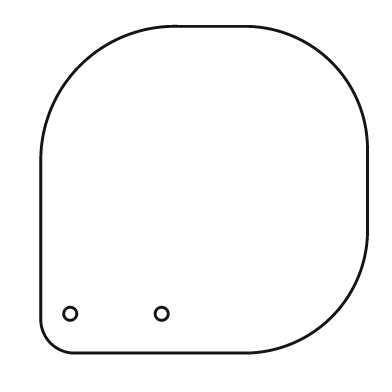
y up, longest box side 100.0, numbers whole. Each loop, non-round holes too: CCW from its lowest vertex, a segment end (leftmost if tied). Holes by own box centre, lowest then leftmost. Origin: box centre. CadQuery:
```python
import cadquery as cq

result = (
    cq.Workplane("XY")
    .moveTo(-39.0, -50.0)
    .lineTo(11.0, -50.0)
    .threePointArc((39.0, -39.0), (50.0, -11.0))
    .lineTo(50.0, 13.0)
    .threePointArc((39.0, 39.0), (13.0, 50.0))
    .lineTo(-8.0, 50.0)
    .threePointArc((-38.0, 38.0), (-50.0, 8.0))
    .lineTo(-50.0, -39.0)
    .threePointArc((-47.0, -47.0), (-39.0, -50.0))
    .close()
    .moveTo(-41.0, -38.0)
    .circle(2.0)
    .moveTo(-13.0, -38.0)
    .circle(2.0)
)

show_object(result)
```